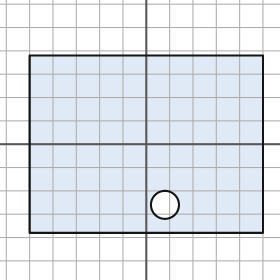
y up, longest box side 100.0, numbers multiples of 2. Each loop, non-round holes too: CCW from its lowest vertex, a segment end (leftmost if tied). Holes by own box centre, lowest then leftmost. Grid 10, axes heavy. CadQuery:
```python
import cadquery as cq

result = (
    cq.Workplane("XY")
    .moveTo(-50.0, -38.0)
    .lineTo(50.0, -38.0)
    .lineTo(50.0, 38.0)
    .lineTo(-50.0, 38.0)
    .close()
    .moveTo(8.0, -26.0)
    .circle(6.0)
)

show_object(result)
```